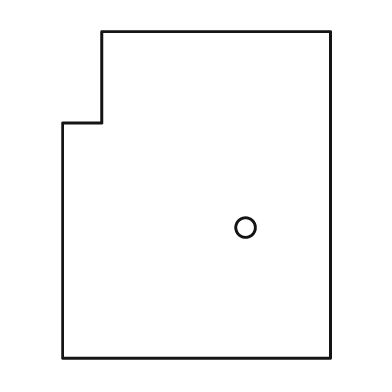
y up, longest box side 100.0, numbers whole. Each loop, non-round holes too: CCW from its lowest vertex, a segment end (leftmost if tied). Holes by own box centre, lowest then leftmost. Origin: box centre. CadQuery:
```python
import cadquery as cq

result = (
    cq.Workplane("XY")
    .moveTo(-41.0, -50.0)
    .lineTo(41.0, -50.0)
    .lineTo(41.0, 50.0)
    .lineTo(-29.0, 50.0)
    .lineTo(-29.0, 22.0)
    .lineTo(-41.0, 22.0)
    .close()
    .moveTo(15.0, -10.0)
    .circle(3.0)
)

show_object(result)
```